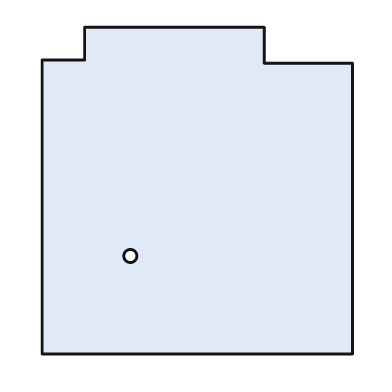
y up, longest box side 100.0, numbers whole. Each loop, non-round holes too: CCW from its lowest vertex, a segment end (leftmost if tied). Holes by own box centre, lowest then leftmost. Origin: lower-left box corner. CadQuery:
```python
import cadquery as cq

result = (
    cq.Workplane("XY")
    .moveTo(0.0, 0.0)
    .lineTo(95.0, 0.0)
    .lineTo(95.0, 89.0)
    .lineTo(68.0, 89.0)
    .lineTo(68.0, 100.0)
    .lineTo(13.0, 100.0)
    .lineTo(13.0, 90.0)
    .lineTo(0.0, 90.0)
    .close()
    .moveTo(27.0, 30.0)
    .circle(2.0)
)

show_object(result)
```